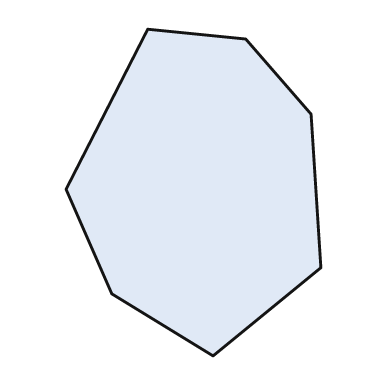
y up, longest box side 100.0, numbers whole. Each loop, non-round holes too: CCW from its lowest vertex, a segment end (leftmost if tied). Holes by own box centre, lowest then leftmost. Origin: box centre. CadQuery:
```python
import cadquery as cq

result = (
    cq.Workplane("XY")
    .moveTo(6.0, -50.0)
    .lineTo(39.0, -23.0)
    .lineTo(36.0, 24.0)
    .lineTo(16.0, 47.0)
    .lineTo(-14.0, 50.0)
    .lineTo(-39.0, 1.0)
    .lineTo(-25.0, -31.0)
    .close()
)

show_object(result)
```